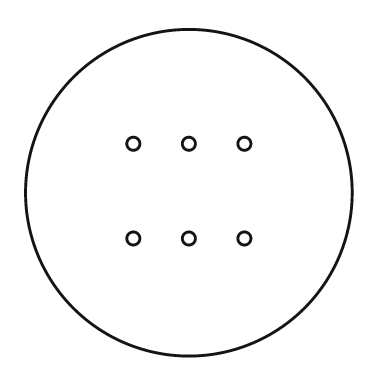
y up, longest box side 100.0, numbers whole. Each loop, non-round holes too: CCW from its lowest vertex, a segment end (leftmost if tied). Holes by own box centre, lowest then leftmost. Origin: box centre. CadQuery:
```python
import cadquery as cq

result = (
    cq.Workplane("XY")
    .moveTo(0.0, 0.0)
    .circle(50.0)
    .moveTo(-17.0, -14.0)
    .circle(2.0)
    .moveTo(0.0, -14.0)
    .circle(2.0)
    .moveTo(17.0, -14.0)
    .circle(2.0)
    .moveTo(-17.0, 15.0)
    .circle(2.0)
    .moveTo(0.0, 15.0)
    .circle(2.0)
    .moveTo(17.0, 15.0)
    .circle(2.0)
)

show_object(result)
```